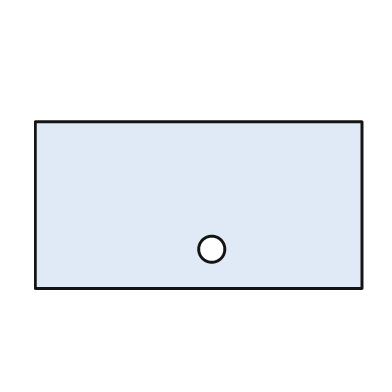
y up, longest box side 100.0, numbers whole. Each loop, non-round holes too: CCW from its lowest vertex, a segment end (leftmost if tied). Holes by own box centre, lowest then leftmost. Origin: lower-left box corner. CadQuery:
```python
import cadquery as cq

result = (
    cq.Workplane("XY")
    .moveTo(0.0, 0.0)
    .lineTo(100.0, 0.0)
    .lineTo(100.0, 51.0)
    .lineTo(0.0, 51.0)
    .close()
    .moveTo(54.0, 12.0)
    .circle(4.0)
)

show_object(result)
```